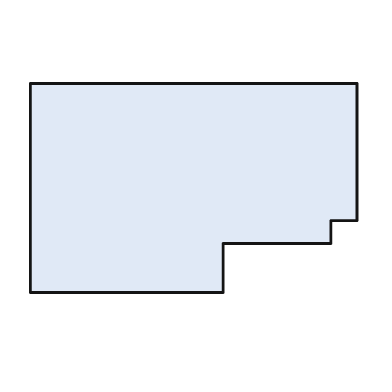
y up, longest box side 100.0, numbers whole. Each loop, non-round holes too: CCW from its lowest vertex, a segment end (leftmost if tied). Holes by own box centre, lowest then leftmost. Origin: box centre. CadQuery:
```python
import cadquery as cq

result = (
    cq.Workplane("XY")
    .moveTo(-50.0, -32.0)
    .lineTo(9.0, -32.0)
    .lineTo(9.0, -17.0)
    .lineTo(42.0, -17.0)
    .lineTo(42.0, -10.0)
    .lineTo(50.0, -10.0)
    .lineTo(50.0, 32.0)
    .lineTo(-50.0, 32.0)
    .close()
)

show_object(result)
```